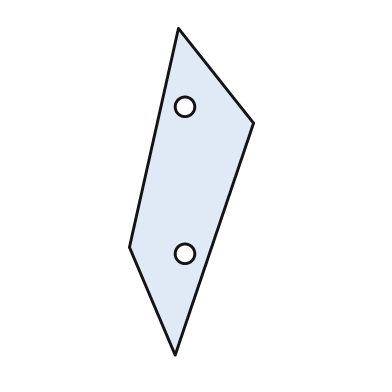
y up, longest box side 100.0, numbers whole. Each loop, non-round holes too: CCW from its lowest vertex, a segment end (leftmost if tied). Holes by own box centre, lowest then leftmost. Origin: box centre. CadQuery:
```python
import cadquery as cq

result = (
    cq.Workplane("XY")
    .moveTo(-5.0, -50.0)
    .lineTo(19.0, 21.0)
    .lineTo(-4.0, 50.0)
    .lineTo(-19.0, -17.0)
    .close()
    .moveTo(-2.0, -19.0)
    .circle(3.0)
    .moveTo(-2.0, 26.0)
    .circle(3.0)
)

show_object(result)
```